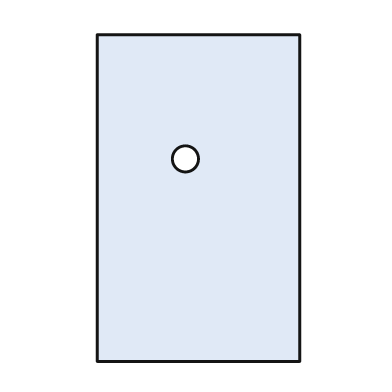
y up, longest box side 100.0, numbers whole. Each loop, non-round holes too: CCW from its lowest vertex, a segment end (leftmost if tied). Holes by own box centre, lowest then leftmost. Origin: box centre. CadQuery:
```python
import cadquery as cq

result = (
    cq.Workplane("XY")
    .moveTo(-31.0, -50.0)
    .lineTo(31.0, -50.0)
    .lineTo(31.0, 50.0)
    .lineTo(-31.0, 50.0)
    .close()
    .moveTo(-4.0, 12.0)
    .circle(4.0)
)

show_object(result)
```